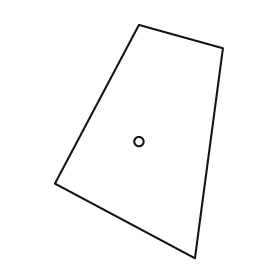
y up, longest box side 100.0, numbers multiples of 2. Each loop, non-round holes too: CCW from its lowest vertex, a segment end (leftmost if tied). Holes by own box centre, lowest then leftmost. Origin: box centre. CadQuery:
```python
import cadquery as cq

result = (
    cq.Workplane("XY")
    .moveTo(24.0, -50.0)
    .lineTo(36.0, 40.0)
    .lineTo(0.0, 50.0)
    .lineTo(-36.0, -18.0)
    .close()
    .moveTo(0.0, 0.0)
    .circle(2.0)
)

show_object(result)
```